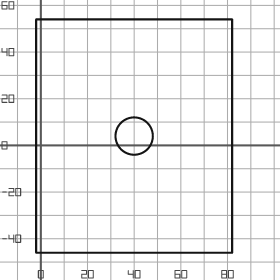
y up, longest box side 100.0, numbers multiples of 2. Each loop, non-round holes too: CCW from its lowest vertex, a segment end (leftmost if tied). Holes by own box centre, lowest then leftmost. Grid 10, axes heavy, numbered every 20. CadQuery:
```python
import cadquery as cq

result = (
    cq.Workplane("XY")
    .moveTo(-2.0, -46.0)
    .lineTo(82.0, -46.0)
    .lineTo(82.0, 54.0)
    .lineTo(-2.0, 54.0)
    .close()
    .moveTo(40.0, 4.0)
    .circle(8.0)
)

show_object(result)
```